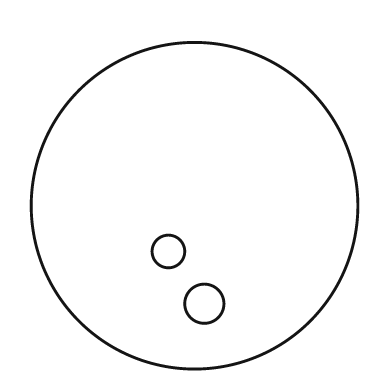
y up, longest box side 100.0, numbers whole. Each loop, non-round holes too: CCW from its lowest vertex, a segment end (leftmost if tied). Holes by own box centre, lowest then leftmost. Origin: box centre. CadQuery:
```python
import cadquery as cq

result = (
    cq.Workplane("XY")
    .moveTo(0.0, 0.0)
    .circle(50.0)
    .moveTo(3.0, -30.0)
    .circle(6.0)
    .moveTo(-8.0, -14.0)
    .circle(5.0)
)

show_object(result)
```